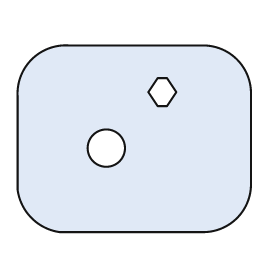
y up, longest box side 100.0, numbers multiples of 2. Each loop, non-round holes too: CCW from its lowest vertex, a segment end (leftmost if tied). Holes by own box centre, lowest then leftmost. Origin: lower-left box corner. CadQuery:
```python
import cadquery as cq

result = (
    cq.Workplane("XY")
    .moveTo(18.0, 0.0)
    .lineTo(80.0, 0.0)
    .threePointArc((94.0, 6.0), (100.0, 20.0))
    .lineTo(100.0, 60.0)
    .threePointArc((94.0, 74.0), (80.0, 80.0))
    .lineTo(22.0, 80.0)
    .threePointArc((6.0, 74.0), (0.0, 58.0))
    .lineTo(0.0, 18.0)
    .threePointArc((6.0, 6.0), (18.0, 0.0))
    .close()
    .moveTo(38.0, 36.0)
    .circle(8.0)
    .moveTo(60.0, 54.0)
    .lineTo(64.0, 54.0)
    .lineTo(68.0, 60.0)
    .lineTo(64.0, 66.0)
    .lineTo(60.0, 66.0)
    .lineTo(56.0, 60.0)
    .close()
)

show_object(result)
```